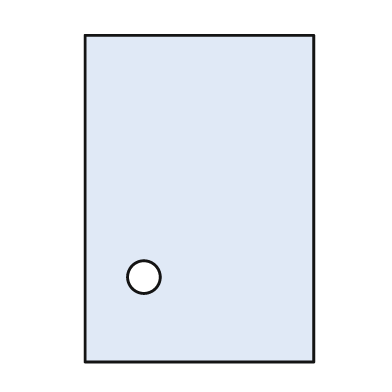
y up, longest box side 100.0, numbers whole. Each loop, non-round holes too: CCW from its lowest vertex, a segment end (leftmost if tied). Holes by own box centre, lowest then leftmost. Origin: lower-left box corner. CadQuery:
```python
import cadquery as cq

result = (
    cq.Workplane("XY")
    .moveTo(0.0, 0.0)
    .lineTo(70.0, 0.0)
    .lineTo(70.0, 100.0)
    .lineTo(0.0, 100.0)
    .close()
    .moveTo(18.0, 26.0)
    .circle(5.0)
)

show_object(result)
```